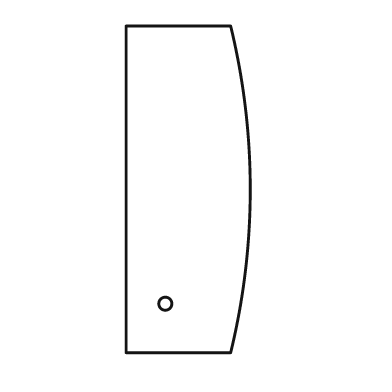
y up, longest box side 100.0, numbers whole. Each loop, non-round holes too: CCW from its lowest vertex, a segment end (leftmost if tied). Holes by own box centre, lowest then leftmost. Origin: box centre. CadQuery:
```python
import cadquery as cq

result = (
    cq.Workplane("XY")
    .moveTo(-19.0, -50.0)
    .lineTo(13.0, -50.0)
    .threePointArc((19.0, 0.0), (13.0, 50.0))
    .lineTo(-19.0, 50.0)
    .close()
    .moveTo(-7.0, -35.0)
    .circle(2.0)
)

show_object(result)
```